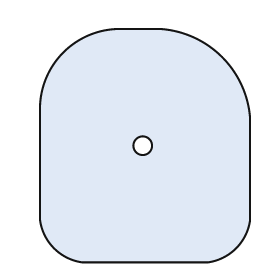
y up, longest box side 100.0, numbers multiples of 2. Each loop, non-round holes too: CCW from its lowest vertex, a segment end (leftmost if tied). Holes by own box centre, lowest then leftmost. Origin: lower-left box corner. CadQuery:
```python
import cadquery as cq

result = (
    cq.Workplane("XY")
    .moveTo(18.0, 0.0)
    .lineTo(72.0, 0.0)
    .threePointArc((84.0, 6.0), (90.0, 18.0))
    .lineTo(90.0, 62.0)
    .threePointArc((78.0, 88.0), (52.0, 100.0))
    .lineTo(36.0, 100.0)
    .threePointArc((10.0, 90.0), (0.0, 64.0))
    .lineTo(0.0, 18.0)
    .threePointArc((6.0, 6.0), (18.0, 0.0))
    .close()
    .moveTo(44.0, 50.0)
    .circle(4.0)
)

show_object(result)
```